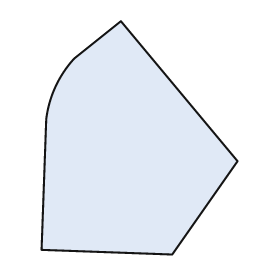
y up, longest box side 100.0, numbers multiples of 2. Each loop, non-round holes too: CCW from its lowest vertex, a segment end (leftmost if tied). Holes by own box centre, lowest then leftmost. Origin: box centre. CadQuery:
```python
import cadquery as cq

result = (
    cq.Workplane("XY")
    .moveTo(14.0, -50.0)
    .lineTo(42.0, -10.0)
    .lineTo(-8.0, 50.0)
    .lineTo(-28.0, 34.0)
    .threePointArc((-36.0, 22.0), (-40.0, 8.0))
    .lineTo(-42.0, -48.0)
    .close()
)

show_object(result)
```